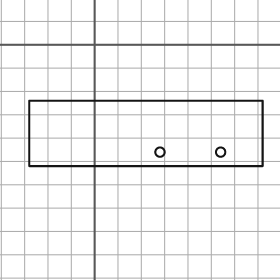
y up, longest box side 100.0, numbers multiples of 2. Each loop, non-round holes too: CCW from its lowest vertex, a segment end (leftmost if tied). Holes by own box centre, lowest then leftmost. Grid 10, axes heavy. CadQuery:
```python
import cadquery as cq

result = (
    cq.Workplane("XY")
    .moveTo(-28.0, -52.0)
    .lineTo(72.0, -52.0)
    .lineTo(72.0, -24.0)
    .lineTo(-28.0, -24.0)
    .close()
    .moveTo(28.0, -46.0)
    .circle(2.0)
    .moveTo(54.0, -46.0)
    .circle(2.0)
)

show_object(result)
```